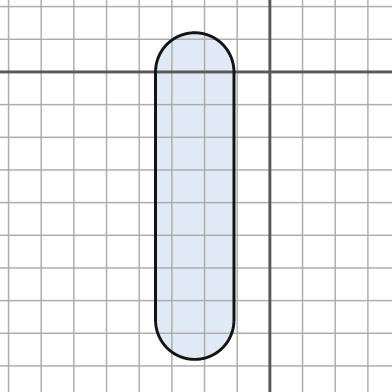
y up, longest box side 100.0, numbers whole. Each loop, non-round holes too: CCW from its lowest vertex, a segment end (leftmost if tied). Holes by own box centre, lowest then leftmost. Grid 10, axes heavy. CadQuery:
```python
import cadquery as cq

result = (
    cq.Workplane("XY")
    .moveTo(-35.0, -76.0)
    .threePointArc((-23.0, -88.0), (-11.0, -76.0))
    .lineTo(-11.0, 0.0)
    .threePointArc((-23.0, 12.0), (-35.0, 0.0))
    .close()
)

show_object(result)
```